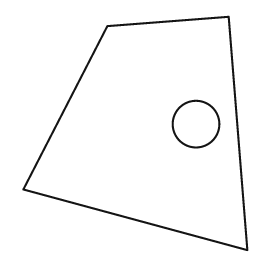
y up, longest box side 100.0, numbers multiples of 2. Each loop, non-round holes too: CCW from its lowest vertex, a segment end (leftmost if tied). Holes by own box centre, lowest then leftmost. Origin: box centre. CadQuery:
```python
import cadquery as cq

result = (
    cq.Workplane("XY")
    .moveTo(48.0, -50.0)
    .lineTo(40.0, 50.0)
    .lineTo(-12.0, 46.0)
    .lineTo(-48.0, -24.0)
    .close()
    .moveTo(26.0, 4.0)
    .circle(10.0)
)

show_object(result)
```